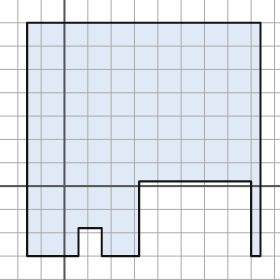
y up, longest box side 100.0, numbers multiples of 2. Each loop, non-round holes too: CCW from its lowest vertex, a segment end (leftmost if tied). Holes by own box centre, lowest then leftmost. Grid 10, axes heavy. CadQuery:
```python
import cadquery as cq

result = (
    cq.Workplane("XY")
    .moveTo(-16.0, -30.0)
    .lineTo(6.0, -30.0)
    .lineTo(6.0, -18.0)
    .lineTo(16.0, -18.0)
    .lineTo(16.0, -30.0)
    .lineTo(32.0, -30.0)
    .lineTo(32.0, 2.0)
    .lineTo(80.0, 2.0)
    .lineTo(80.0, -30.0)
    .lineTo(84.0, -30.0)
    .lineTo(84.0, 70.0)
    .lineTo(-16.0, 70.0)
    .close()
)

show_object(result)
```